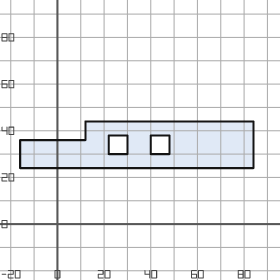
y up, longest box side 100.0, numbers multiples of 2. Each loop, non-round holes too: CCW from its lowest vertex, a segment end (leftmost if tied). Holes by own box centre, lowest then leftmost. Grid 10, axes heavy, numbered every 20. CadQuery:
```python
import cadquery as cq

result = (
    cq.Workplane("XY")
    .moveTo(-16.0, 24.0)
    .lineTo(84.0, 24.0)
    .lineTo(84.0, 44.0)
    .lineTo(12.0, 44.0)
    .lineTo(12.0, 36.0)
    .lineTo(-16.0, 36.0)
    .close()
    .moveTo(22.0, 30.0)
    .lineTo(30.0, 30.0)
    .lineTo(30.0, 38.0)
    .lineTo(22.0, 38.0)
    .close()
    .moveTo(40.0, 30.0)
    .lineTo(48.0, 30.0)
    .lineTo(48.0, 38.0)
    .lineTo(40.0, 38.0)
    .close()
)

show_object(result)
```